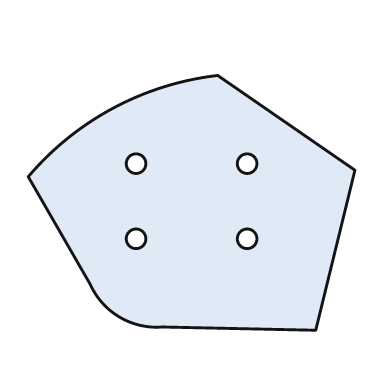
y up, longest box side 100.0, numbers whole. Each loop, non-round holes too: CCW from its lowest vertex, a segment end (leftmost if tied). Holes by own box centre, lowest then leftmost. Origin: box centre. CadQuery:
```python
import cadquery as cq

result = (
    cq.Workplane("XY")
    .moveTo(38.0, -39.0)
    .lineTo(50.0, 10.0)
    .lineTo(8.0, 39.0)
    .threePointArc((-24.0, 29.0), (-50.0, 8.0))
    .lineTo(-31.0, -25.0)
    .threePointArc((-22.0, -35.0), (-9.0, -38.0))
    .close()
    .moveTo(-17.0, -11.0)
    .circle(3.0)
    .moveTo(17.0, -11.0)
    .circle(3.0)
    .moveTo(-17.0, 12.0)
    .circle(3.0)
    .moveTo(17.0, 12.0)
    .circle(3.0)
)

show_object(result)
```